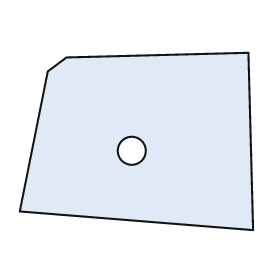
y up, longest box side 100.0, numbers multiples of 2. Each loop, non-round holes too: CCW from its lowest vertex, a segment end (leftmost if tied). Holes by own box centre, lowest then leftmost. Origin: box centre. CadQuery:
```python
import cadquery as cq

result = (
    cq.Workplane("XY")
    .moveTo(50.0, -38.0)
    .lineTo(48.0, 38.0)
    .lineTo(-30.0, 36.0)
    .lineTo(-38.0, 30.0)
    .lineTo(-50.0, -30.0)
    .close()
    .moveTo(-2.0, -4.0)
    .circle(6.0)
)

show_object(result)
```